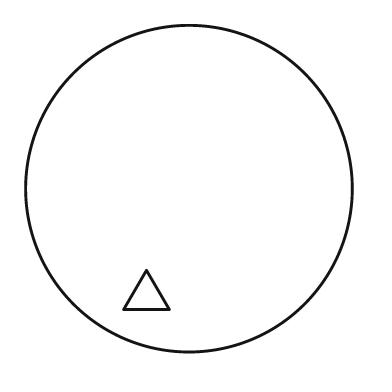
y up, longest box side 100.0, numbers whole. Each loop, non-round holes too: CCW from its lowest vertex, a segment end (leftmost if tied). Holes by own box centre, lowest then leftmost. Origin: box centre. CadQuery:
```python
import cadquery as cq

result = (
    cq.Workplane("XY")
    .moveTo(0.0, 0.0)
    .circle(50.0)
    .moveTo(-20.0, -37.0)
    .lineTo(-6.0, -37.0)
    .lineTo(-13.0, -25.0)
    .close()
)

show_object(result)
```